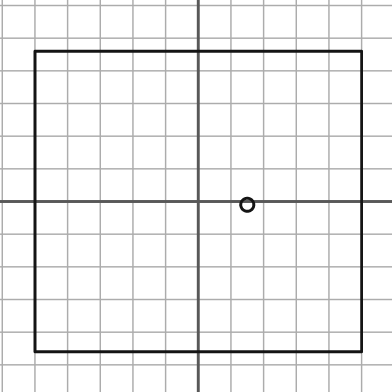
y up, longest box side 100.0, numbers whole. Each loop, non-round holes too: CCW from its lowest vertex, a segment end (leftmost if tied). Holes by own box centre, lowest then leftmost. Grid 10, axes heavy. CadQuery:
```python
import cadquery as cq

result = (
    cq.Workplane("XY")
    .moveTo(-50.0, -46.0)
    .lineTo(50.0, -46.0)
    .lineTo(50.0, 46.0)
    .lineTo(-50.0, 46.0)
    .close()
    .moveTo(15.0, -1.0)
    .circle(2.0)
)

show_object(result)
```